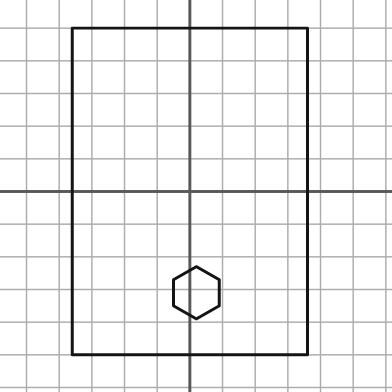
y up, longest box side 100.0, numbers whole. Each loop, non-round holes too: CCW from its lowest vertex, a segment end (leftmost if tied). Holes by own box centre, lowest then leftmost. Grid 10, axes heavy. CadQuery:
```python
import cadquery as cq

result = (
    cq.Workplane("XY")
    .moveTo(-36.0, -50.0)
    .lineTo(36.0, -50.0)
    .lineTo(36.0, 50.0)
    .lineTo(-36.0, 50.0)
    .close()
    .moveTo(2.0, -39.0)
    .lineTo(9.0, -35.0)
    .lineTo(9.0, -27.0)
    .lineTo(2.0, -23.0)
    .lineTo(-5.0, -27.0)
    .lineTo(-5.0, -35.0)
    .close()
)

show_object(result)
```